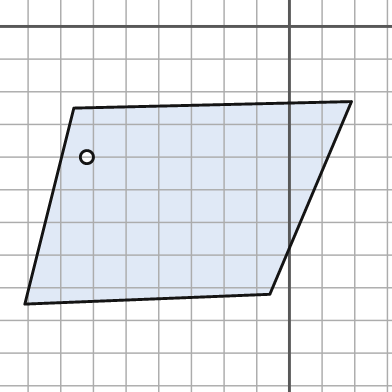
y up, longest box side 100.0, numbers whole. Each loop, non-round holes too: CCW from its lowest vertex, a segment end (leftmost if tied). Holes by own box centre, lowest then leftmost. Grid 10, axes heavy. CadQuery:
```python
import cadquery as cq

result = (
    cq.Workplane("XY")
    .moveTo(-81.0, -85.0)
    .lineTo(-6.0, -82.0)
    .lineTo(19.0, -23.0)
    .lineTo(-66.0, -25.0)
    .close()
    .moveTo(-62.0, -40.0)
    .circle(2.0)
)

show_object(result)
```